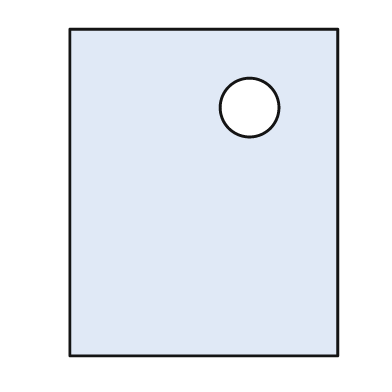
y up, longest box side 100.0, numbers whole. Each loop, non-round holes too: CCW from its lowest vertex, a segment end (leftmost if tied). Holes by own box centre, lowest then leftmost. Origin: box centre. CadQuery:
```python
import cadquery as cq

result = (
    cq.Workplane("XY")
    .moveTo(-41.0, -50.0)
    .lineTo(41.0, -50.0)
    .lineTo(41.0, 50.0)
    .lineTo(-41.0, 50.0)
    .close()
    .moveTo(14.0, 26.0)
    .circle(9.0)
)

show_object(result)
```